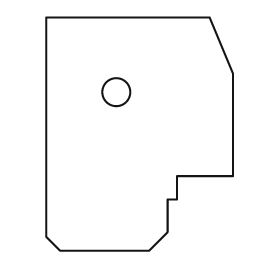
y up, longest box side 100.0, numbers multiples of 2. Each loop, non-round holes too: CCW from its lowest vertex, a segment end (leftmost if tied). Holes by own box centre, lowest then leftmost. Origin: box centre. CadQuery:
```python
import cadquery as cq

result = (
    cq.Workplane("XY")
    .moveTo(-34.0, -50.0)
    .lineTo(4.0, -50.0)
    .lineTo(12.0, -42.0)
    .lineTo(12.0, -28.0)
    .lineTo(16.0, -28.0)
    .lineTo(16.0, -18.0)
    .lineTo(40.0, -18.0)
    .lineTo(40.0, 26.0)
    .lineTo(30.0, 50.0)
    .lineTo(-40.0, 50.0)
    .lineTo(-40.0, -44.0)
    .close()
    .moveTo(-10.0, 18.0)
    .circle(6.0)
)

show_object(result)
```